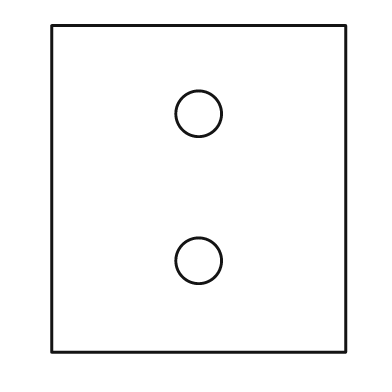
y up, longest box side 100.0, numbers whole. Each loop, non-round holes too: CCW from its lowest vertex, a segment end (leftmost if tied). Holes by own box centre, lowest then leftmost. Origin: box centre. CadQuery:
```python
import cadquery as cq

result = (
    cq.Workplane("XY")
    .moveTo(-45.0, -50.0)
    .lineTo(45.0, -50.0)
    .lineTo(45.0, 50.0)
    .lineTo(-45.0, 50.0)
    .close()
    .moveTo(0.0, -22.0)
    .circle(7.0)
    .moveTo(0.0, 23.0)
    .circle(7.0)
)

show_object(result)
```